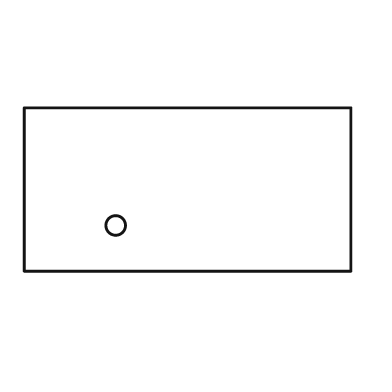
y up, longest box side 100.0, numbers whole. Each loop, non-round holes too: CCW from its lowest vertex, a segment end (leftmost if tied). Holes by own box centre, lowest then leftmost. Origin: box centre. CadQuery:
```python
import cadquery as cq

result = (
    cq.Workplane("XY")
    .moveTo(-50.0, -25.0)
    .lineTo(50.0, -25.0)
    .lineTo(50.0, 25.0)
    .lineTo(-50.0, 25.0)
    .close()
    .moveTo(-22.0, -11.0)
    .circle(3.0)
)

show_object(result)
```